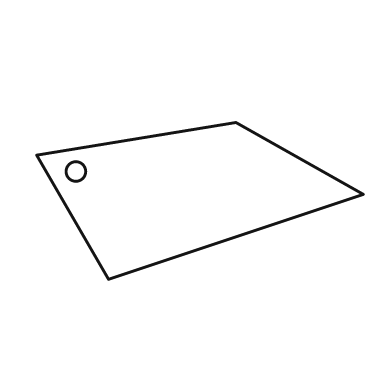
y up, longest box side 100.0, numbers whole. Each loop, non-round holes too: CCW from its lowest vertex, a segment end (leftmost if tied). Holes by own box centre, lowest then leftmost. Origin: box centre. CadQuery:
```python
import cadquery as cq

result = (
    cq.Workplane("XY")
    .moveTo(-28.0, -24.0)
    .lineTo(50.0, 2.0)
    .lineTo(11.0, 24.0)
    .lineTo(-50.0, 14.0)
    .close()
    .moveTo(-38.0, 9.0)
    .circle(3.0)
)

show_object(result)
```